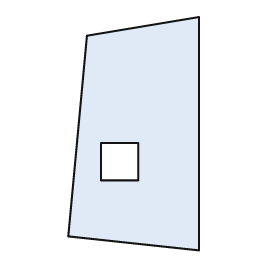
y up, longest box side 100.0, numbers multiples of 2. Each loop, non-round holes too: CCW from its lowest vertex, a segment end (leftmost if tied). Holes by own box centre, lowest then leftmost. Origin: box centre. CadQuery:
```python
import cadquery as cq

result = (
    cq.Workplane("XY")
    .moveTo(28.0, -50.0)
    .lineTo(28.0, 50.0)
    .lineTo(-20.0, 42.0)
    .lineTo(-28.0, -44.0)
    .close()
    .moveTo(-14.0, -20.0)
    .lineTo(2.0, -20.0)
    .lineTo(2.0, -4.0)
    .lineTo(-14.0, -4.0)
    .close()
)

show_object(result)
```